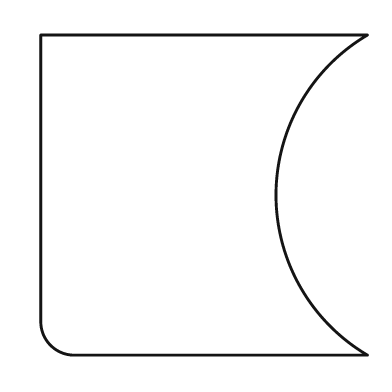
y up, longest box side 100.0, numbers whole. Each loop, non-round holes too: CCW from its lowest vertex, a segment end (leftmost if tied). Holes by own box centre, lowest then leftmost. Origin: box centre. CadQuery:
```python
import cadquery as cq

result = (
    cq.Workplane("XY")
    .moveTo(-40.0, -49.0)
    .lineTo(50.0, -49.0)
    .threePointArc((22.0, 0.0), (50.0, 49.0))
    .lineTo(-50.0, 49.0)
    .lineTo(-50.0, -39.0)
    .threePointArc((-47.0, -46.0), (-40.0, -49.0))
    .close()
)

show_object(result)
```